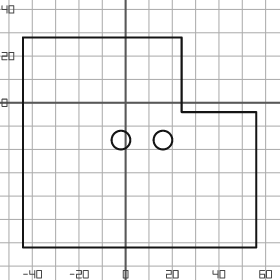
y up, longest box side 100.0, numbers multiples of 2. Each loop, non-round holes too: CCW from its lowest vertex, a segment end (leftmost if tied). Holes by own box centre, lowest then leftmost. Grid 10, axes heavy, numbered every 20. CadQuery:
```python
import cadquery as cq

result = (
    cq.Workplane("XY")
    .moveTo(-44.0, -62.0)
    .lineTo(56.0, -62.0)
    .lineTo(56.0, -4.0)
    .lineTo(24.0, -4.0)
    .lineTo(24.0, 28.0)
    .lineTo(-44.0, 28.0)
    .close()
    .moveTo(-2.0, -16.0)
    .circle(4.0)
    .moveTo(16.0, -16.0)
    .circle(4.0)
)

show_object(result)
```